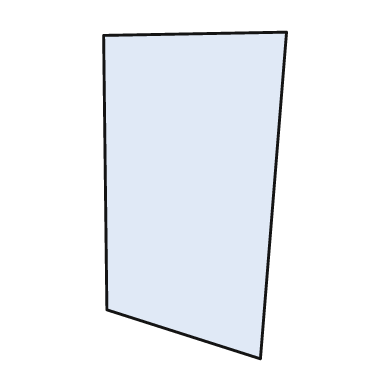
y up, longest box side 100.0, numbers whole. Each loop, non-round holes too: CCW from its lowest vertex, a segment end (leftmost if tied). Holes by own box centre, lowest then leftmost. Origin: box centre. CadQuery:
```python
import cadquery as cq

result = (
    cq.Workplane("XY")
    .moveTo(20.0, -50.0)
    .lineTo(28.0, 50.0)
    .lineTo(-28.0, 49.0)
    .lineTo(-27.0, -35.0)
    .close()
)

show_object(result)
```